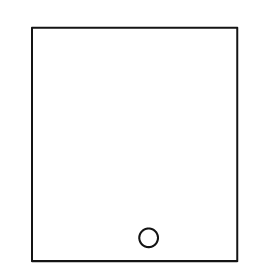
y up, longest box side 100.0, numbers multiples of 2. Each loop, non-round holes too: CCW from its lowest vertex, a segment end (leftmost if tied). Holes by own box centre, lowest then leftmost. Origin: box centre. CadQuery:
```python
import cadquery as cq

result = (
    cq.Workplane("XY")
    .moveTo(-44.0, -50.0)
    .lineTo(44.0, -50.0)
    .lineTo(44.0, 50.0)
    .lineTo(-44.0, 50.0)
    .close()
    .moveTo(6.0, -40.0)
    .circle(4.0)
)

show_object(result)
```